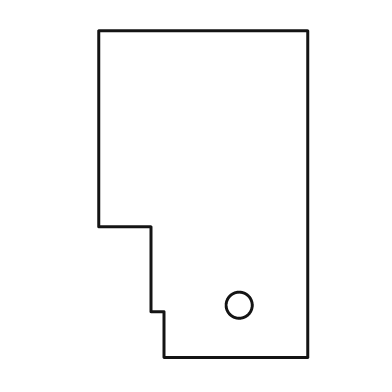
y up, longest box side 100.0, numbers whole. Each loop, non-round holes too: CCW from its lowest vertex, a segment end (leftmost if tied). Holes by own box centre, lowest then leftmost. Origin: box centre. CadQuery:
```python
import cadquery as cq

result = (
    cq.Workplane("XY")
    .moveTo(-12.0, -50.0)
    .lineTo(32.0, -50.0)
    .lineTo(32.0, 50.0)
    .lineTo(-32.0, 50.0)
    .lineTo(-32.0, -10.0)
    .lineTo(-16.0, -10.0)
    .lineTo(-16.0, -36.0)
    .lineTo(-12.0, -36.0)
    .close()
    .moveTo(11.0, -34.0)
    .circle(4.0)
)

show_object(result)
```